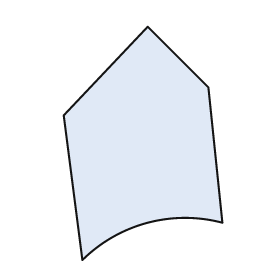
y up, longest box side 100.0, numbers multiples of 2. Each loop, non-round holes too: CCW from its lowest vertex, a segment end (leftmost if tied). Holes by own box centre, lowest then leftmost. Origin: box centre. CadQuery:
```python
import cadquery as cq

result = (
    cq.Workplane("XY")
    .moveTo(-26.0, -50.0)
    .threePointArc((2.0, -34.0), (34.0, -34.0))
    .lineTo(28.0, 24.0)
    .lineTo(2.0, 50.0)
    .lineTo(-34.0, 12.0)
    .close()
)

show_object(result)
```